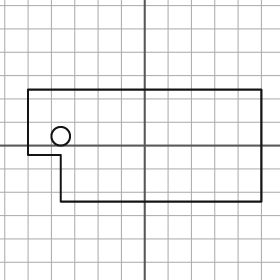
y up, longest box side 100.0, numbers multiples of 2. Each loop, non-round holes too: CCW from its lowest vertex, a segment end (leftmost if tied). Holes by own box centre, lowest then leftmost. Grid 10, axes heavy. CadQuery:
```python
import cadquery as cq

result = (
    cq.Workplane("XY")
    .moveTo(-36.0, -24.0)
    .lineTo(50.0, -24.0)
    .lineTo(50.0, 24.0)
    .lineTo(-50.0, 24.0)
    .lineTo(-50.0, -4.0)
    .lineTo(-36.0, -4.0)
    .close()
    .moveTo(-36.0, 4.0)
    .circle(4.0)
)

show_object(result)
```